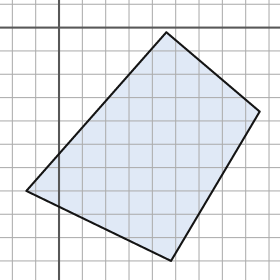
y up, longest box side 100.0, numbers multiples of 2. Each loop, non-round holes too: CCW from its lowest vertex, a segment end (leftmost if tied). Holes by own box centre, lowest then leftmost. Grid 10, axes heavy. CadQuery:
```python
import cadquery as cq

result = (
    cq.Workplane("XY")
    .moveTo(48.0, -100.0)
    .lineTo(86.0, -36.0)
    .lineTo(46.0, -2.0)
    .lineTo(-14.0, -70.0)
    .close()
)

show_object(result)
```